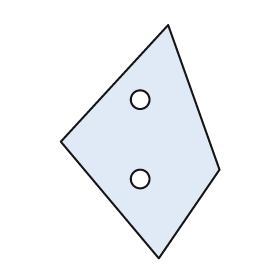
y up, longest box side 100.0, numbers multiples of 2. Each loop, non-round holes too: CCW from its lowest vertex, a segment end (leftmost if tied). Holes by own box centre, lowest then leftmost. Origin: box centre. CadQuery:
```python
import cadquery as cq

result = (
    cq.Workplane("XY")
    .moveTo(8.0, -50.0)
    .lineTo(34.0, -12.0)
    .lineTo(12.0, 50.0)
    .lineTo(-34.0, 0.0)
    .close()
    .moveTo(0.0, -16.0)
    .circle(4.0)
    .moveTo(0.0, 18.0)
    .circle(4.0)
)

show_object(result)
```